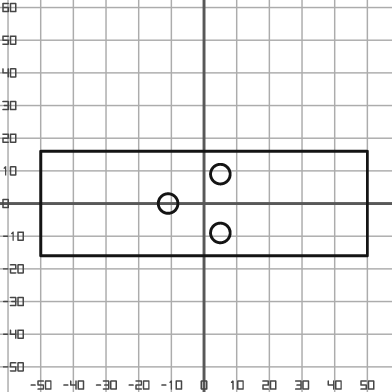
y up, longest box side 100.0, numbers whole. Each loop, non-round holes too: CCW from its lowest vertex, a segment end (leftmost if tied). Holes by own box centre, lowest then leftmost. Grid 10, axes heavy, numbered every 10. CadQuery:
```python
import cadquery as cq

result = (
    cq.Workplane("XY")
    .moveTo(-50.0, -16.0)
    .lineTo(50.0, -16.0)
    .lineTo(50.0, 16.0)
    .lineTo(-50.0, 16.0)
    .close()
    .moveTo(5.0, -9.0)
    .circle(3.0)
    .moveTo(-11.0, 0.0)
    .circle(3.0)
    .moveTo(5.0, 9.0)
    .circle(3.0)
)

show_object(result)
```